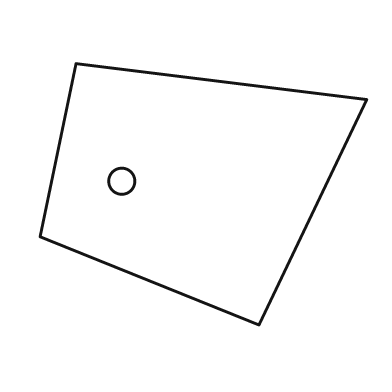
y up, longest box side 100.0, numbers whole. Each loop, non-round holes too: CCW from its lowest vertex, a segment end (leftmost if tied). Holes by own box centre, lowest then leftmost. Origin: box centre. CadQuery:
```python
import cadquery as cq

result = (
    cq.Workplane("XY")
    .moveTo(17.0, -40.0)
    .lineTo(50.0, 29.0)
    .lineTo(-39.0, 40.0)
    .lineTo(-50.0, -13.0)
    .close()
    .moveTo(-25.0, 4.0)
    .circle(4.0)
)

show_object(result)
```